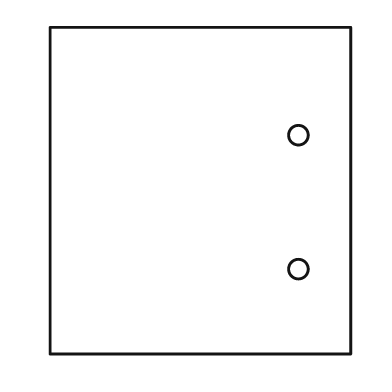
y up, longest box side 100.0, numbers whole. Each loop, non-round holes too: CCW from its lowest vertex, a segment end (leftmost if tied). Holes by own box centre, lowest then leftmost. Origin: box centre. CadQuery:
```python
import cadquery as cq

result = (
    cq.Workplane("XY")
    .moveTo(-46.0, -50.0)
    .lineTo(46.0, -50.0)
    .lineTo(46.0, 50.0)
    .lineTo(-46.0, 50.0)
    .close()
    .moveTo(30.0, -24.0)
    .circle(3.0)
    .moveTo(30.0, 17.0)
    .circle(3.0)
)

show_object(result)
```